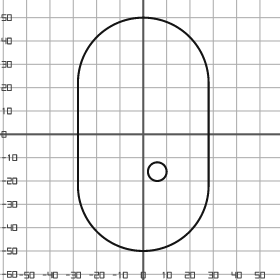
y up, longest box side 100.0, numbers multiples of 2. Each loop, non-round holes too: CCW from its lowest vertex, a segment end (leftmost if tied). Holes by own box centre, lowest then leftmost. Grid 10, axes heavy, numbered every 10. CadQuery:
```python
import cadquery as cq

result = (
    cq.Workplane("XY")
    .moveTo(-28.0, -22.0)
    .threePointArc((0.0, -50.0), (28.0, -22.0))
    .lineTo(28.0, 22.0)
    .threePointArc((0.0, 50.0), (-28.0, 22.0))
    .close()
    .moveTo(6.0, -16.0)
    .circle(4.0)
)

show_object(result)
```